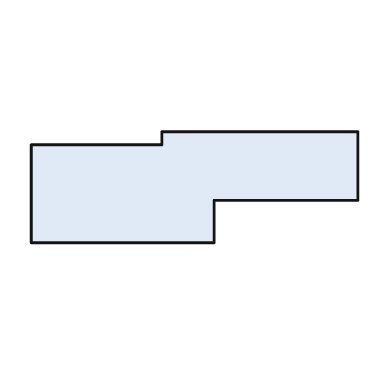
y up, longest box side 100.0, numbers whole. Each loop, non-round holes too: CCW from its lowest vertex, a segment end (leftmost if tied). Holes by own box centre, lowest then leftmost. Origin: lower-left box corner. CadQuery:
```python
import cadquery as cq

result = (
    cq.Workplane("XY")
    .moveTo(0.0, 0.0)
    .lineTo(56.0, 0.0)
    .lineTo(56.0, 13.0)
    .lineTo(100.0, 13.0)
    .lineTo(100.0, 34.0)
    .lineTo(40.0, 34.0)
    .lineTo(40.0, 30.0)
    .lineTo(0.0, 30.0)
    .close()
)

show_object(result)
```